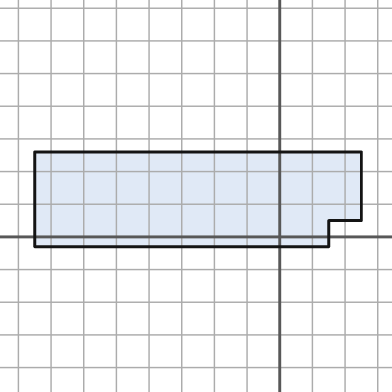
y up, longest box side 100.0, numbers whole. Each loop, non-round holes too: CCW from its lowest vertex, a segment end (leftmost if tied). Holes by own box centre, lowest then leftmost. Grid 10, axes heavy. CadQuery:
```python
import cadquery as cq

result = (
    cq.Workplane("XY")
    .moveTo(-75.0, -3.0)
    .lineTo(15.0, -3.0)
    .lineTo(15.0, 5.0)
    .lineTo(25.0, 5.0)
    .lineTo(25.0, 26.0)
    .lineTo(-75.0, 26.0)
    .close()
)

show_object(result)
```